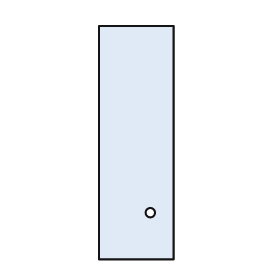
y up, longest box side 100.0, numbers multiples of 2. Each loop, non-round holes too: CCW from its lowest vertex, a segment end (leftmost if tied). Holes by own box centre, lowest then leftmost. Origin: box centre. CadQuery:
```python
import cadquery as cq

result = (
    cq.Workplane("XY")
    .moveTo(-16.0, -50.0)
    .lineTo(16.0, -50.0)
    .lineTo(16.0, 50.0)
    .lineTo(-16.0, 50.0)
    .close()
    .moveTo(6.0, -30.0)
    .circle(2.0)
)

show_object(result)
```